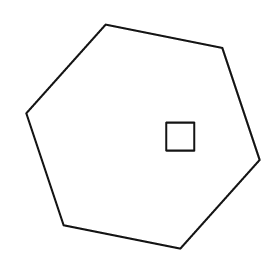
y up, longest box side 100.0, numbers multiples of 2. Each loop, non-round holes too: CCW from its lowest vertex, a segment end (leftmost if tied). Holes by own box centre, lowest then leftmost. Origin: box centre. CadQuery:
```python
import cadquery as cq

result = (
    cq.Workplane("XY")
    .moveTo(16.0, -48.0)
    .lineTo(50.0, -10.0)
    .lineTo(34.0, 38.0)
    .lineTo(-16.0, 48.0)
    .lineTo(-50.0, 10.0)
    .lineTo(-34.0, -38.0)
    .close()
    .moveTo(10.0, -6.0)
    .lineTo(22.0, -6.0)
    .lineTo(22.0, 6.0)
    .lineTo(10.0, 6.0)
    .close()
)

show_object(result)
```